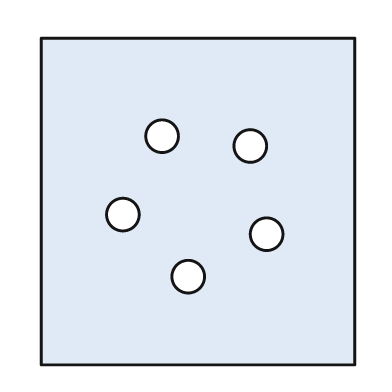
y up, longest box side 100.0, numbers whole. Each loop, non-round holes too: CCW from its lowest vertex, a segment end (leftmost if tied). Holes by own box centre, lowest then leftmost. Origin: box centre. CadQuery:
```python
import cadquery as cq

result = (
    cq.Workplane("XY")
    .moveTo(-48.0, -50.0)
    .lineTo(48.0, -50.0)
    .lineTo(48.0, 50.0)
    .lineTo(-48.0, 50.0)
    .close()
    .moveTo(-3.0, -23.0)
    .circle(5.0)
    .moveTo(21.0, -10.0)
    .circle(5.0)
    .moveTo(-23.0, -4.0)
    .circle(5.0)
    .moveTo(16.0, 17.0)
    .circle(5.0)
    .moveTo(-11.0, 20.0)
    .circle(5.0)
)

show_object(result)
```